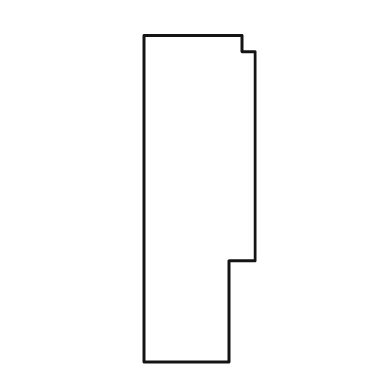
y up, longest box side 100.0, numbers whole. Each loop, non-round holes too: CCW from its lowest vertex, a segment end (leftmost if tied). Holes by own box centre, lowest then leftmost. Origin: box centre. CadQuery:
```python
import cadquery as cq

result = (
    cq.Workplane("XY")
    .moveTo(-17.0, -50.0)
    .lineTo(9.0, -50.0)
    .lineTo(9.0, -19.0)
    .lineTo(17.0, -19.0)
    .lineTo(17.0, 45.0)
    .lineTo(13.0, 45.0)
    .lineTo(13.0, 50.0)
    .lineTo(-17.0, 50.0)
    .close()
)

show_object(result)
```